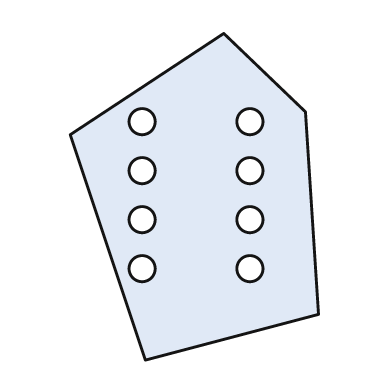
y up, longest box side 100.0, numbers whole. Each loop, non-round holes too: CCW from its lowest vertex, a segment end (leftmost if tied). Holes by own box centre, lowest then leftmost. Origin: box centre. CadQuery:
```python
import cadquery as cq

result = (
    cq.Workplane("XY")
    .moveTo(-15.0, -50.0)
    .lineTo(38.0, -36.0)
    .lineTo(34.0, 26.0)
    .lineTo(9.0, 50.0)
    .lineTo(-38.0, 19.0)
    .close()
    .moveTo(-16.0, -22.0)
    .circle(4.0)
    .moveTo(17.0, -22.0)
    .circle(4.0)
    .moveTo(-16.0, -7.0)
    .circle(4.0)
    .moveTo(17.0, -7.0)
    .circle(4.0)
    .moveTo(-16.0, 8.0)
    .circle(4.0)
    .moveTo(17.0, 8.0)
    .circle(4.0)
    .moveTo(-16.0, 23.0)
    .circle(4.0)
    .moveTo(17.0, 23.0)
    .circle(4.0)
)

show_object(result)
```